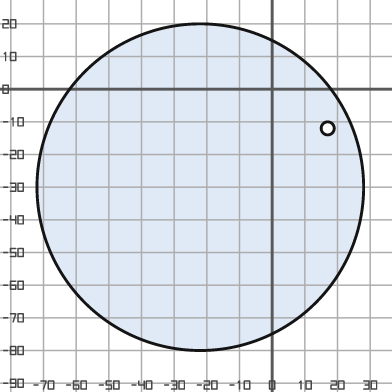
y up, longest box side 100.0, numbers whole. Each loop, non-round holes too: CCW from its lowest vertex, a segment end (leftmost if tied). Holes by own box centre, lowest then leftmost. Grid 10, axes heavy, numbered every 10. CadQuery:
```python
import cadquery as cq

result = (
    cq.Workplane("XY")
    .moveTo(-22.0, -30.0)
    .circle(50.0)
    .moveTo(17.0, -12.0)
    .circle(2.0)
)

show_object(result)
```